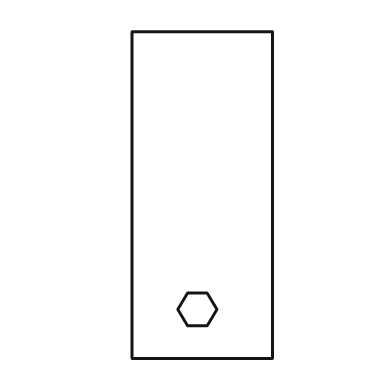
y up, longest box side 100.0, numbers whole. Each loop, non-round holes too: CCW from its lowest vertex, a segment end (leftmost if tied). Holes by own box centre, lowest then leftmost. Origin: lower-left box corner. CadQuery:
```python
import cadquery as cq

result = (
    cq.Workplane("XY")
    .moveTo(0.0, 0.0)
    .lineTo(43.0, 0.0)
    .lineTo(43.0, 100.0)
    .lineTo(0.0, 100.0)
    .close()
    .moveTo(17.0, 10.0)
    .lineTo(23.0, 10.0)
    .lineTo(26.0, 15.0)
    .lineTo(23.0, 20.0)
    .lineTo(17.0, 20.0)
    .lineTo(14.0, 15.0)
    .close()
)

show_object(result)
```